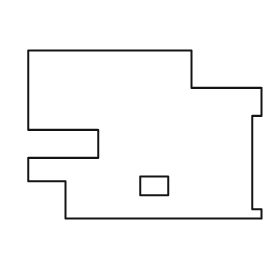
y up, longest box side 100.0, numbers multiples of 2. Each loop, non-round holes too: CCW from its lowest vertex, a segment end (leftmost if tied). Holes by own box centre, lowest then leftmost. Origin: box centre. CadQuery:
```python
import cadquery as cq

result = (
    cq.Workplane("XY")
    .moveTo(-34.0, -36.0)
    .lineTo(50.0, -36.0)
    .lineTo(50.0, -32.0)
    .lineTo(46.0, -32.0)
    .lineTo(46.0, 8.0)
    .lineTo(50.0, 8.0)
    .lineTo(50.0, 20.0)
    .lineTo(20.0, 20.0)
    .lineTo(20.0, 36.0)
    .lineTo(-50.0, 36.0)
    .lineTo(-50.0, 2.0)
    .lineTo(-20.0, 2.0)
    .lineTo(-20.0, -10.0)
    .lineTo(-50.0, -10.0)
    .lineTo(-50.0, -20.0)
    .lineTo(-34.0, -20.0)
    .close()
    .moveTo(-2.0, -26.0)
    .lineTo(10.0, -26.0)
    .lineTo(10.0, -18.0)
    .lineTo(-2.0, -18.0)
    .close()
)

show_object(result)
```